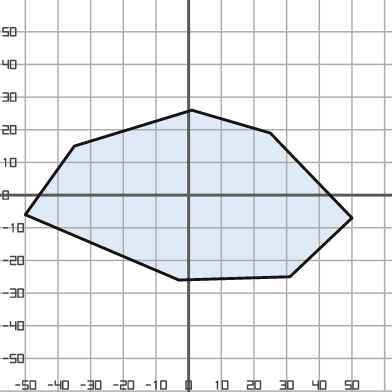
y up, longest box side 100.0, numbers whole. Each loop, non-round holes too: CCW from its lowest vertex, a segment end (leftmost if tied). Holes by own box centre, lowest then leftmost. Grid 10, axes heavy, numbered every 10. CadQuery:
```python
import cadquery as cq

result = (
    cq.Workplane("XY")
    .moveTo(-3.0, -26.0)
    .lineTo(31.0, -25.0)
    .lineTo(50.0, -7.0)
    .lineTo(25.0, 19.0)
    .lineTo(1.0, 26.0)
    .lineTo(-35.0, 15.0)
    .lineTo(-50.0, -6.0)
    .close()
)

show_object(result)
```